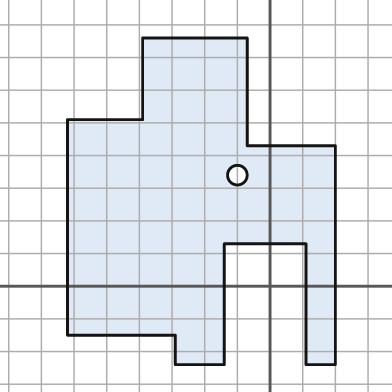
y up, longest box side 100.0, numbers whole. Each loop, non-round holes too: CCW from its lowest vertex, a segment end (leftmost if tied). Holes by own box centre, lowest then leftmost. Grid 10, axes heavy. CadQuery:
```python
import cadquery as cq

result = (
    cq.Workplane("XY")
    .moveTo(-29.0, -24.0)
    .lineTo(-14.0, -24.0)
    .lineTo(-14.0, 13.0)
    .lineTo(11.0, 13.0)
    .lineTo(11.0, -24.0)
    .lineTo(20.0, -24.0)
    .lineTo(20.0, 43.0)
    .lineTo(-7.0, 43.0)
    .lineTo(-7.0, 76.0)
    .lineTo(-39.0, 76.0)
    .lineTo(-39.0, 51.0)
    .lineTo(-62.0, 51.0)
    .lineTo(-62.0, -15.0)
    .lineTo(-29.0, -15.0)
    .close()
    .moveTo(-10.0, 34.0)
    .circle(3.0)
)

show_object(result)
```